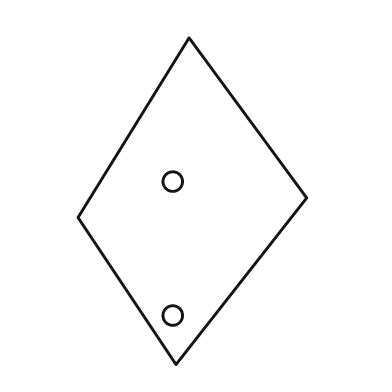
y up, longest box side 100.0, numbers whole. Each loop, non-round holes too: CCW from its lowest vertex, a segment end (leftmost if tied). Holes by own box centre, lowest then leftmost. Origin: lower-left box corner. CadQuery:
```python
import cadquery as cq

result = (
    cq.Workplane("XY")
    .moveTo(30.0, 0.0)
    .lineTo(70.0, 51.0)
    .lineTo(34.0, 100.0)
    .lineTo(0.0, 45.0)
    .close()
    .moveTo(29.0, 15.0)
    .circle(3.0)
    .moveTo(29.0, 56.0)
    .circle(3.0)
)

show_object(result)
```